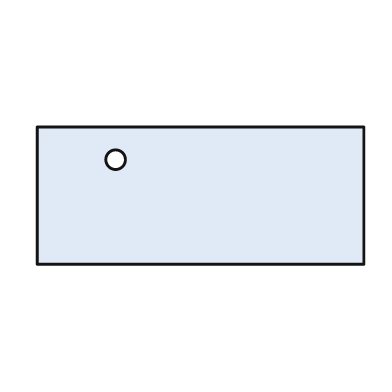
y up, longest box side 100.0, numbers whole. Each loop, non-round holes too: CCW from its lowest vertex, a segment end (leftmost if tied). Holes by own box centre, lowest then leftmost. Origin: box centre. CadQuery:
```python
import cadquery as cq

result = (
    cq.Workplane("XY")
    .moveTo(-50.0, -21.0)
    .lineTo(50.0, -21.0)
    .lineTo(50.0, 21.0)
    .lineTo(-50.0, 21.0)
    .close()
    .moveTo(-26.0, 11.0)
    .circle(3.0)
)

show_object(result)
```